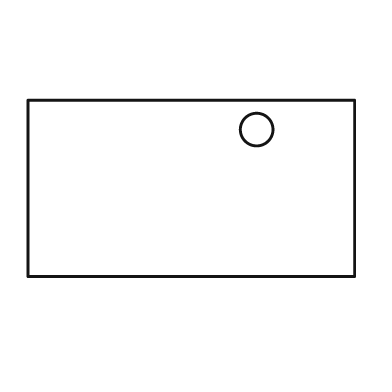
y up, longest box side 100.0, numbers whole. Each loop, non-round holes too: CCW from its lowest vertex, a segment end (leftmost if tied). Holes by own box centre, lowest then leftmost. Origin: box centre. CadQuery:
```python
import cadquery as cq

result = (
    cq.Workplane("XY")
    .moveTo(-50.0, -27.0)
    .lineTo(50.0, -27.0)
    .lineTo(50.0, 27.0)
    .lineTo(-50.0, 27.0)
    .close()
    .moveTo(20.0, 18.0)
    .circle(5.0)
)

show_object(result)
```